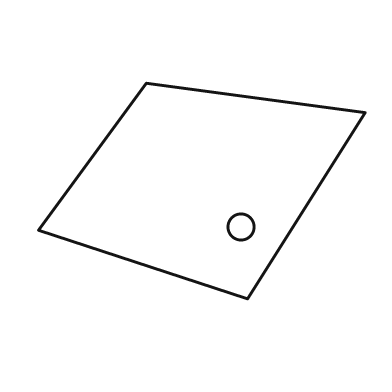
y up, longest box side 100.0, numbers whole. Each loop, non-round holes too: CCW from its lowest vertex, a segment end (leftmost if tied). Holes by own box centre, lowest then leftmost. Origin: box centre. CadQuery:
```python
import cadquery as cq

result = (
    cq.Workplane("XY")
    .moveTo(14.0, -33.0)
    .lineTo(50.0, 24.0)
    .lineTo(-17.0, 33.0)
    .lineTo(-50.0, -12.0)
    .close()
    .moveTo(12.0, -11.0)
    .circle(4.0)
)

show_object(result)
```